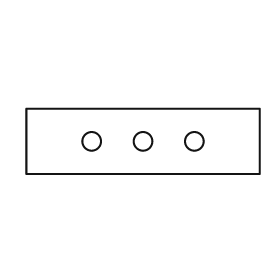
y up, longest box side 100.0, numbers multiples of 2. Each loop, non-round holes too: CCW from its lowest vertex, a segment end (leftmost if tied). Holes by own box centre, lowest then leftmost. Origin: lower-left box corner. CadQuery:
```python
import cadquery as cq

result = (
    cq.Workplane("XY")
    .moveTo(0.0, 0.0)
    .lineTo(100.0, 0.0)
    .lineTo(100.0, 28.0)
    .lineTo(0.0, 28.0)
    .close()
    .moveTo(28.0, 14.0)
    .circle(4.0)
    .moveTo(50.0, 14.0)
    .circle(4.0)
    .moveTo(72.0, 14.0)
    .circle(4.0)
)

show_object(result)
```